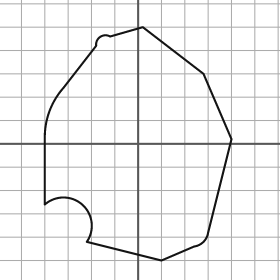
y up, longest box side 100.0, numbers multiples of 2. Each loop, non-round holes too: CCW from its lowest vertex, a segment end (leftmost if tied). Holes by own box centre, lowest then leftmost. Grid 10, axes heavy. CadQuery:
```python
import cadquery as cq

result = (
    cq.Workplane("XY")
    .moveTo(10.0, -50.0)
    .lineTo(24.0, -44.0)
    .threePointArc((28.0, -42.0), (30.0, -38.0))
    .lineTo(40.0, 2.0)
    .lineTo(28.0, 30.0)
    .lineTo(2.0, 50.0)
    .lineTo(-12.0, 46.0)
    .threePointArc((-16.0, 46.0), (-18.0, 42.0))
    .lineTo(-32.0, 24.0)
    .threePointArc((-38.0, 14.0), (-40.0, 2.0))
    .lineTo(-40.0, -26.0)
    .threePointArc((-24.0, -26.0), (-22.0, -42.0))
    .close()
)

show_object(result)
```